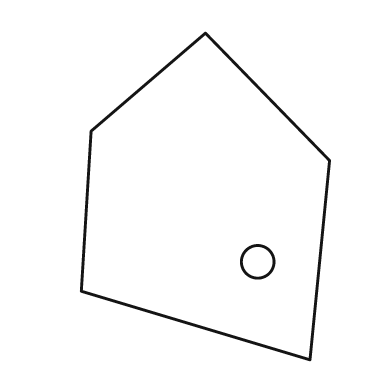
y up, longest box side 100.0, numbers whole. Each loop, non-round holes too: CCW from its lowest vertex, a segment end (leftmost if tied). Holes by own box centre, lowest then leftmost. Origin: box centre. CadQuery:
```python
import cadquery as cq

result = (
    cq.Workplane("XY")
    .moveTo(32.0, -50.0)
    .lineTo(38.0, 11.0)
    .lineTo(0.0, 50.0)
    .lineTo(-35.0, 20.0)
    .lineTo(-38.0, -29.0)
    .close()
    .moveTo(16.0, -20.0)
    .circle(5.0)
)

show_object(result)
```